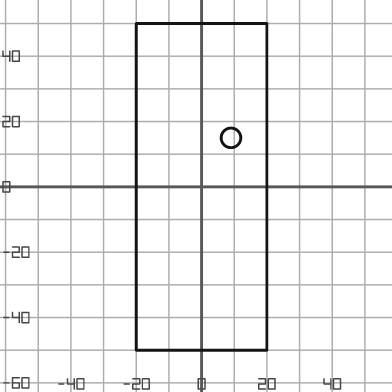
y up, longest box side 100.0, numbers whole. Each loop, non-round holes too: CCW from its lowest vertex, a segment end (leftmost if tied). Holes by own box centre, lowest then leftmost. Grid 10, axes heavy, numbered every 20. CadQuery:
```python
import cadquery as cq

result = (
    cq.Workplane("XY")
    .moveTo(-20.0, -50.0)
    .lineTo(20.0, -50.0)
    .lineTo(20.0, 50.0)
    .lineTo(-20.0, 50.0)
    .close()
    .moveTo(9.0, 15.0)
    .circle(3.0)
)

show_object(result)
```